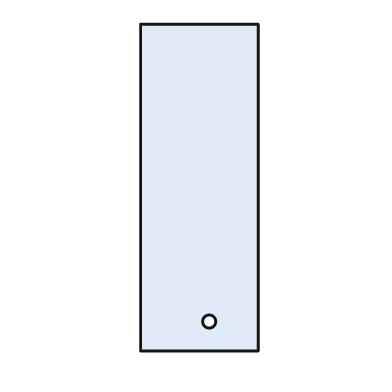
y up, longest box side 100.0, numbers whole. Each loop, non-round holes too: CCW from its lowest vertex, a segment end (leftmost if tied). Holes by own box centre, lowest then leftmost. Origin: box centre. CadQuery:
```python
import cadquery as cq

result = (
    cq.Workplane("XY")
    .moveTo(-18.0, -50.0)
    .lineTo(18.0, -50.0)
    .lineTo(18.0, 50.0)
    .lineTo(-18.0, 50.0)
    .close()
    .moveTo(3.0, -41.0)
    .circle(2.0)
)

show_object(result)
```